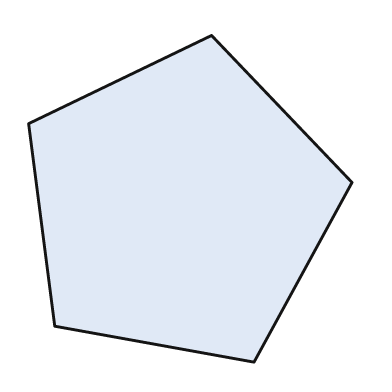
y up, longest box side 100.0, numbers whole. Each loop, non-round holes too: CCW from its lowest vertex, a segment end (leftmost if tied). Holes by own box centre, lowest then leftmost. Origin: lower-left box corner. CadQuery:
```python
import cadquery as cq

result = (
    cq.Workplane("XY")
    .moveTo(69.0, 0.0)
    .lineTo(99.0, 55.0)
    .lineTo(56.0, 100.0)
    .lineTo(0.0, 73.0)
    .lineTo(8.0, 11.0)
    .close()
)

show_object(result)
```